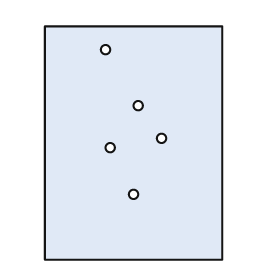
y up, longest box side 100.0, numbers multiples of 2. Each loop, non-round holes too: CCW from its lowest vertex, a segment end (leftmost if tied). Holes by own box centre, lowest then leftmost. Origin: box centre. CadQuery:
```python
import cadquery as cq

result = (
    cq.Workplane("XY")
    .moveTo(-38.0, -50.0)
    .lineTo(38.0, -50.0)
    .lineTo(38.0, 50.0)
    .lineTo(-38.0, 50.0)
    .close()
    .moveTo(0.0, -22.0)
    .circle(2.0)
    .moveTo(-10.0, -2.0)
    .circle(2.0)
    .moveTo(12.0, 2.0)
    .circle(2.0)
    .moveTo(2.0, 16.0)
    .circle(2.0)
    .moveTo(-12.0, 40.0)
    .circle(2.0)
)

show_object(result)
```